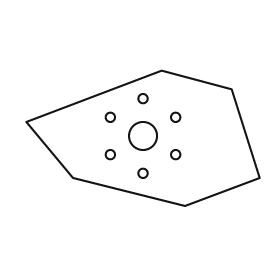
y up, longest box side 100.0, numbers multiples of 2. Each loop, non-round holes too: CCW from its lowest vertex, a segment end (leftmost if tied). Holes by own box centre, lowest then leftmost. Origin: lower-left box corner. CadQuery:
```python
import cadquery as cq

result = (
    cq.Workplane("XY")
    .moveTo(68.0, 0.0)
    .lineTo(100.0, 12.0)
    .lineTo(88.0, 50.0)
    .lineTo(58.0, 58.0)
    .lineTo(0.0, 36.0)
    .lineTo(20.0, 12.0)
    .close()
    .moveTo(50.0, 14.0)
    .circle(2.0)
    .moveTo(36.0, 22.0)
    .circle(2.0)
    .moveTo(64.0, 22.0)
    .circle(2.0)
    .moveTo(50.0, 30.0)
    .circle(6.0)
    .moveTo(36.0, 38.0)
    .circle(2.0)
    .moveTo(64.0, 38.0)
    .circle(2.0)
    .moveTo(50.0, 46.0)
    .circle(2.0)
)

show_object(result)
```